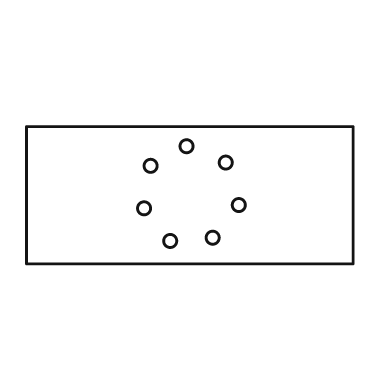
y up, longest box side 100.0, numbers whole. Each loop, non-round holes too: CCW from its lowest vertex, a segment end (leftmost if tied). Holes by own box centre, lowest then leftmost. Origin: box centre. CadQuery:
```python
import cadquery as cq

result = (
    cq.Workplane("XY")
    .moveTo(-50.0, -21.0)
    .lineTo(50.0, -21.0)
    .lineTo(50.0, 21.0)
    .lineTo(-50.0, 21.0)
    .close()
    .moveTo(-6.0, -14.0)
    .circle(2.0)
    .moveTo(7.0, -13.0)
    .circle(2.0)
    .moveTo(-14.0, -4.0)
    .circle(2.0)
    .moveTo(15.0, -3.0)
    .circle(2.0)
    .moveTo(-12.0, 9.0)
    .circle(2.0)
    .moveTo(11.0, 10.0)
    .circle(2.0)
    .moveTo(-1.0, 15.0)
    .circle(2.0)
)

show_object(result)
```